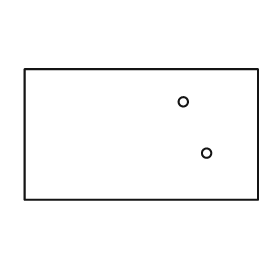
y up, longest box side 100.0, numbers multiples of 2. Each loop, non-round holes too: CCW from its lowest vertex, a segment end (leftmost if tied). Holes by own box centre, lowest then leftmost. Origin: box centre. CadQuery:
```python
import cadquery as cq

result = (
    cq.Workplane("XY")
    .moveTo(-50.0, -28.0)
    .lineTo(50.0, -28.0)
    .lineTo(50.0, 28.0)
    .lineTo(-50.0, 28.0)
    .close()
    .moveTo(28.0, -8.0)
    .circle(2.0)
    .moveTo(18.0, 14.0)
    .circle(2.0)
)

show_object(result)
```